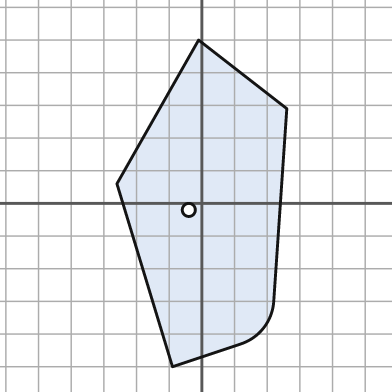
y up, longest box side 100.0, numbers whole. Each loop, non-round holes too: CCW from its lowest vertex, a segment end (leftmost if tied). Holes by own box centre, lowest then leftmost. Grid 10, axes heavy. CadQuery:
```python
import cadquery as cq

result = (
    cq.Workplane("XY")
    .moveTo(-9.0, -50.0)
    .lineTo(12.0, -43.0)
    .threePointArc((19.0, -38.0), (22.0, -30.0))
    .lineTo(26.0, 29.0)
    .lineTo(-1.0, 50.0)
    .lineTo(-26.0, 6.0)
    .close()
    .moveTo(-4.0, -2.0)
    .circle(2.0)
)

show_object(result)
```